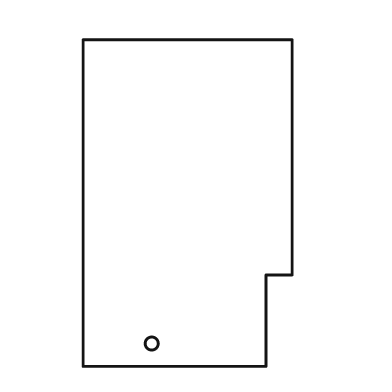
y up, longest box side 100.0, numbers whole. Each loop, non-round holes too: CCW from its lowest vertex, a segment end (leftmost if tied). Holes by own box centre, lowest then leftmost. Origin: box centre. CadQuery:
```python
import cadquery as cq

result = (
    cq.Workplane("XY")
    .moveTo(-32.0, -50.0)
    .lineTo(24.0, -50.0)
    .lineTo(24.0, -22.0)
    .lineTo(32.0, -22.0)
    .lineTo(32.0, 50.0)
    .lineTo(-32.0, 50.0)
    .close()
    .moveTo(-11.0, -43.0)
    .circle(2.0)
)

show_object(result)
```